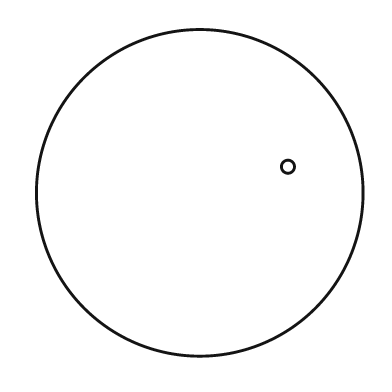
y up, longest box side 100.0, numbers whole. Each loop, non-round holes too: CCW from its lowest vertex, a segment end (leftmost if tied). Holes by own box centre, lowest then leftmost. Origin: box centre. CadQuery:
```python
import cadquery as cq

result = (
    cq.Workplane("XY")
    .moveTo(0.0, 0.0)
    .circle(50.0)
    .moveTo(27.0, 8.0)
    .circle(2.0)
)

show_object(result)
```